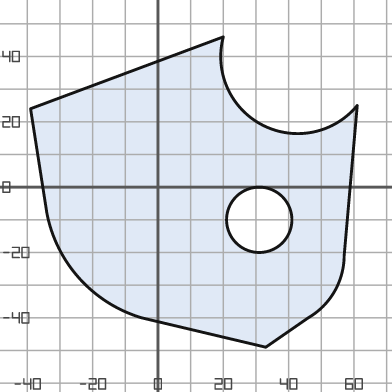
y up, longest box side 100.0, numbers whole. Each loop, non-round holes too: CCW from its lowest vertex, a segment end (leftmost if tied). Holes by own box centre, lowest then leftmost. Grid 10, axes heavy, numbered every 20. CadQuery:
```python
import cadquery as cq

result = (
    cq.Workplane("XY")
    .moveTo(33.0, -49.0)
    .lineTo(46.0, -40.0)
    .threePointArc((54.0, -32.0), (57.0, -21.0))
    .lineTo(61.0, 25.0)
    .threePointArc((32.0, 19.0), (20.0, 46.0))
    .lineTo(-39.0, 24.0)
    .lineTo(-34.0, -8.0)
    .threePointArc((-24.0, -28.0), (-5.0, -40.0))
    .close()
    .moveTo(31.0, -10.0)
    .circle(10.0)
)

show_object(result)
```